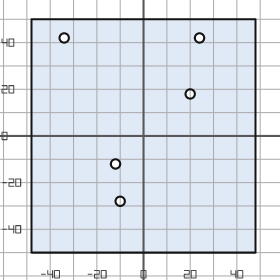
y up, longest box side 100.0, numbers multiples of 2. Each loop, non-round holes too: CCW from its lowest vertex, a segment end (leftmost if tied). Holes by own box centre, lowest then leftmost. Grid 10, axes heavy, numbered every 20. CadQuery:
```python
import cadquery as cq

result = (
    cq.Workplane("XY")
    .moveTo(-48.0, -50.0)
    .lineTo(48.0, -50.0)
    .lineTo(48.0, 50.0)
    .lineTo(-48.0, 50.0)
    .close()
    .moveTo(-10.0, -28.0)
    .circle(2.0)
    .moveTo(-12.0, -12.0)
    .circle(2.0)
    .moveTo(20.0, 18.0)
    .circle(2.0)
    .moveTo(-34.0, 42.0)
    .circle(2.0)
    .moveTo(24.0, 42.0)
    .circle(2.0)
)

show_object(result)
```